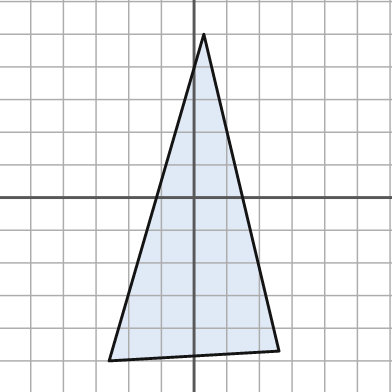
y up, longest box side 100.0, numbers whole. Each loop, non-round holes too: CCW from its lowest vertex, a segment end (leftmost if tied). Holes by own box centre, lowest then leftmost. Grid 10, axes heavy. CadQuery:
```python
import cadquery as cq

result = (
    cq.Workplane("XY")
    .moveTo(-26.0, -50.0)
    .lineTo(26.0, -47.0)
    .lineTo(3.0, 50.0)
    .close()
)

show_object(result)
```